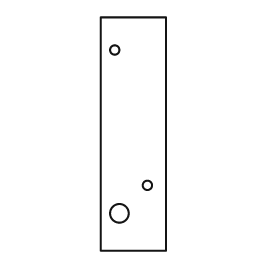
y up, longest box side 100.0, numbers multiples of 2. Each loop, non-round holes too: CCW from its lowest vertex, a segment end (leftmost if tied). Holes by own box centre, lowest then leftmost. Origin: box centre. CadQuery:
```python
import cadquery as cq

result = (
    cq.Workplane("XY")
    .moveTo(-14.0, -50.0)
    .lineTo(14.0, -50.0)
    .lineTo(14.0, 50.0)
    .lineTo(-14.0, 50.0)
    .close()
    .moveTo(-6.0, -34.0)
    .circle(4.0)
    .moveTo(6.0, -22.0)
    .circle(2.0)
    .moveTo(-8.0, 36.0)
    .circle(2.0)
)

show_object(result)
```